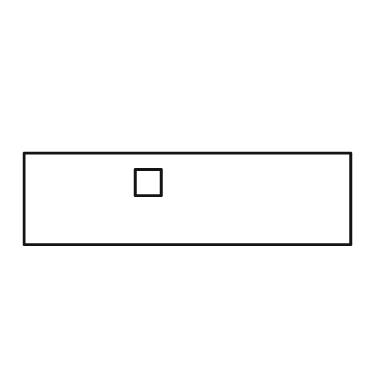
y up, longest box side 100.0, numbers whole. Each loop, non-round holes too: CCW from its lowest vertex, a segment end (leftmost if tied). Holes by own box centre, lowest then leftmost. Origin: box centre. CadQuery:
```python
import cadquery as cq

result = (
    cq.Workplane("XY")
    .moveTo(-50.0, -14.0)
    .lineTo(50.0, -14.0)
    .lineTo(50.0, 14.0)
    .lineTo(-50.0, 14.0)
    .close()
    .moveTo(-16.0, 1.0)
    .lineTo(-8.0, 1.0)
    .lineTo(-8.0, 9.0)
    .lineTo(-16.0, 9.0)
    .close()
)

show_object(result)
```